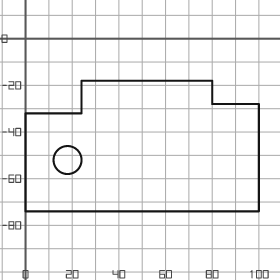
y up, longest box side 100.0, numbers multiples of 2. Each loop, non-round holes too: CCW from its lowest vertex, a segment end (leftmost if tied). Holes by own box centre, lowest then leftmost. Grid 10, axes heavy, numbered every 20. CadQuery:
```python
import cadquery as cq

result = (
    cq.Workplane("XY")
    .moveTo(0.0, -74.0)
    .lineTo(100.0, -74.0)
    .lineTo(100.0, -28.0)
    .lineTo(80.0, -28.0)
    .lineTo(80.0, -18.0)
    .lineTo(24.0, -18.0)
    .lineTo(24.0, -32.0)
    .lineTo(0.0, -32.0)
    .close()
    .moveTo(18.0, -52.0)
    .circle(6.0)
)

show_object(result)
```